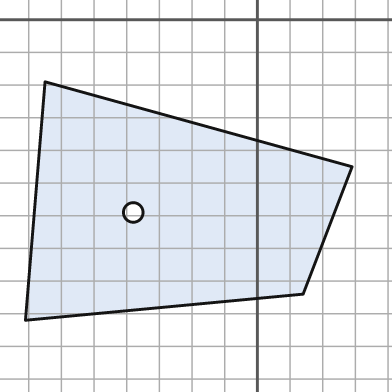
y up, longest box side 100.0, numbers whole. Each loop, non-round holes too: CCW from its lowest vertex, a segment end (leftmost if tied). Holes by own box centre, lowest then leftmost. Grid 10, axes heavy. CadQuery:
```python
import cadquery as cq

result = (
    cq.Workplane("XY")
    .moveTo(-71.0, -92.0)
    .lineTo(14.0, -84.0)
    .lineTo(29.0, -45.0)
    .lineTo(-65.0, -19.0)
    .close()
    .moveTo(-38.0, -59.0)
    .circle(3.0)
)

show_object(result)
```